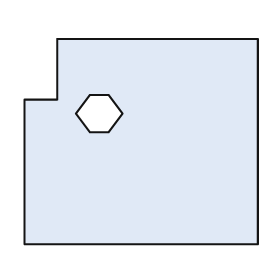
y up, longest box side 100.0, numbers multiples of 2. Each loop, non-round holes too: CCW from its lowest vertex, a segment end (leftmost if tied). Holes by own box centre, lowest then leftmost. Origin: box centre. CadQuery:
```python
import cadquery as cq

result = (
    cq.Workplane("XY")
    .moveTo(-50.0, -44.0)
    .lineTo(50.0, -44.0)
    .lineTo(50.0, 44.0)
    .lineTo(-36.0, 44.0)
    .lineTo(-36.0, 18.0)
    .lineTo(-50.0, 18.0)
    .close()
    .moveTo(-22.0, 4.0)
    .lineTo(-14.0, 4.0)
    .lineTo(-8.0, 12.0)
    .lineTo(-14.0, 20.0)
    .lineTo(-22.0, 20.0)
    .lineTo(-28.0, 12.0)
    .close()
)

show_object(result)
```